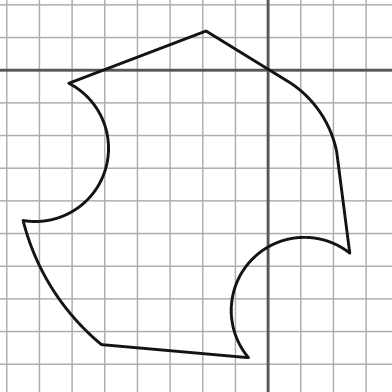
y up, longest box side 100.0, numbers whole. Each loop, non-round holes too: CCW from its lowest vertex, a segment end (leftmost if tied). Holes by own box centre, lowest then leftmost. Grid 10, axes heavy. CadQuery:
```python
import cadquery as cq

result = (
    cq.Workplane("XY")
    .moveTo(-6.0, -88.0)
    .threePointArc((-5.0, -58.0), (25.0, -56.0))
    .lineTo(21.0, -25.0)
    .threePointArc((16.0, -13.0), (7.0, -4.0))
    .lineTo(-19.0, 12.0)
    .lineTo(-61.0, -4.0)
    .threePointArc((-50.0, -31.0), (-75.0, -46.0))
    .threePointArc((-66.0, -67.0), (-51.0, -84.0))
    .close()
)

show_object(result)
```